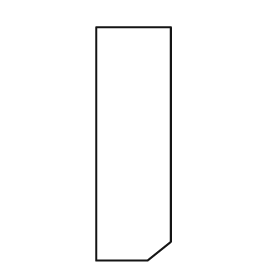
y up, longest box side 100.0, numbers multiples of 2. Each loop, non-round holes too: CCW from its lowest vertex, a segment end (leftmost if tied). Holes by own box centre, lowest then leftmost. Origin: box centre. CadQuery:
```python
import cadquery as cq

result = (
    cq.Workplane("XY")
    .moveTo(-16.0, -50.0)
    .lineTo(6.0, -50.0)
    .lineTo(16.0, -42.0)
    .lineTo(16.0, 50.0)
    .lineTo(-16.0, 50.0)
    .close()
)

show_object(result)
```